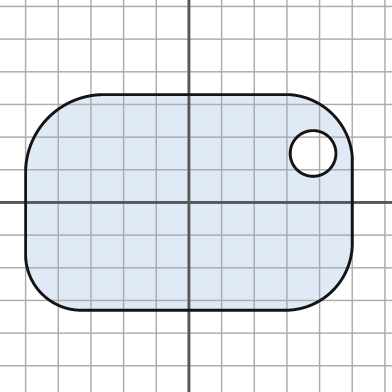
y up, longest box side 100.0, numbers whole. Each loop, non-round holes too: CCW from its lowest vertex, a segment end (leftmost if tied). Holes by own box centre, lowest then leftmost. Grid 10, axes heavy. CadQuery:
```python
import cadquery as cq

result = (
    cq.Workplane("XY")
    .moveTo(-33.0, -33.0)
    .lineTo(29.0, -33.0)
    .threePointArc((44.0, -27.0), (50.0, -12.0))
    .lineTo(50.0, 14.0)
    .threePointArc((44.0, 27.0), (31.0, 33.0))
    .lineTo(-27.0, 33.0)
    .threePointArc((-43.0, 26.0), (-50.0, 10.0))
    .lineTo(-50.0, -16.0)
    .threePointArc((-45.0, -28.0), (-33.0, -33.0))
    .close()
    .moveTo(38.0, 15.0)
    .circle(7.0)
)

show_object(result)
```